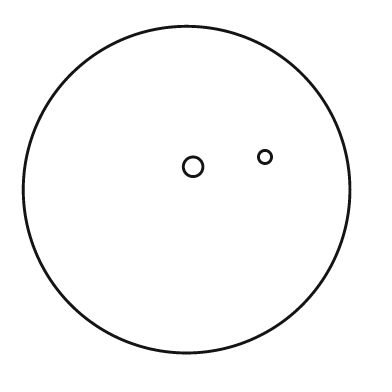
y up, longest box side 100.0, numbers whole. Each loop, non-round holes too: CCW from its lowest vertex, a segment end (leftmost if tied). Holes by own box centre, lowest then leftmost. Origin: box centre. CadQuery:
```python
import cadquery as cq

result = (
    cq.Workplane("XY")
    .moveTo(0.0, 0.0)
    .circle(50.0)
    .moveTo(2.0, 7.0)
    .circle(3.0)
    .moveTo(24.0, 10.0)
    .circle(2.0)
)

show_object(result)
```